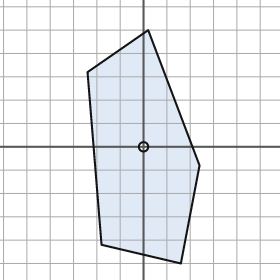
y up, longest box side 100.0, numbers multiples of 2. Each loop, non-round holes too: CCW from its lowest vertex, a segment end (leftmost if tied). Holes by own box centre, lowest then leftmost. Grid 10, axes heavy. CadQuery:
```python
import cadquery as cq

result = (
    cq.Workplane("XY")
    .moveTo(16.0, -50.0)
    .lineTo(24.0, -8.0)
    .lineTo(2.0, 50.0)
    .lineTo(-24.0, 32.0)
    .lineTo(-18.0, -42.0)
    .close()
    .moveTo(0.0, 0.0)
    .circle(2.0)
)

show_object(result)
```